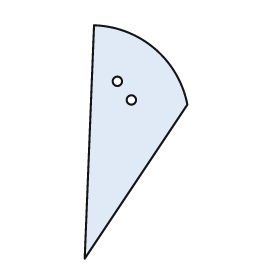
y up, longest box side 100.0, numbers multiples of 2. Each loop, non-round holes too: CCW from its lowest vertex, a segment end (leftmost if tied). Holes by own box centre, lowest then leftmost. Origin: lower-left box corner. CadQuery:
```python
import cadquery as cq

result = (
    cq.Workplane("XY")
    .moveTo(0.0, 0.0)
    .lineTo(44.0, 66.0)
    .threePointArc((30.0, 90.0), (4.0, 100.0))
    .close()
    .moveTo(20.0, 68.0)
    .circle(2.0)
    .moveTo(14.0, 76.0)
    .circle(2.0)
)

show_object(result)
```